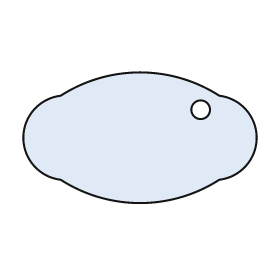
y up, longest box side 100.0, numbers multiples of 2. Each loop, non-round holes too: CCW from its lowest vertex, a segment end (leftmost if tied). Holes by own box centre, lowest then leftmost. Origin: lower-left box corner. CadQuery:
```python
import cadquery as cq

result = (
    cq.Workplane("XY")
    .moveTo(16.0, 10.0)
    .threePointArc((50.0, 0.0), (84.0, 10.0))
    .threePointArc((100.0, 28.0), (84.0, 46.0))
    .threePointArc((50.0, 56.0), (16.0, 46.0))
    .threePointArc((0.0, 28.0), (16.0, 10.0))
    .close()
    .moveTo(76.0, 40.0)
    .circle(4.0)
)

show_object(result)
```